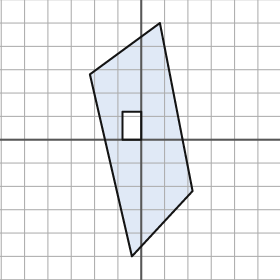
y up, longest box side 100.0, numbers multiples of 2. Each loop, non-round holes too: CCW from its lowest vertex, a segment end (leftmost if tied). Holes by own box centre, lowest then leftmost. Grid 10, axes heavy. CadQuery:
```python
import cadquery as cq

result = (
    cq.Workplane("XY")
    .moveTo(-4.0, -50.0)
    .lineTo(22.0, -22.0)
    .lineTo(8.0, 50.0)
    .lineTo(-22.0, 28.0)
    .close()
    .moveTo(-8.0, 0.0)
    .lineTo(0.0, 0.0)
    .lineTo(0.0, 12.0)
    .lineTo(-8.0, 12.0)
    .close()
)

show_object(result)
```